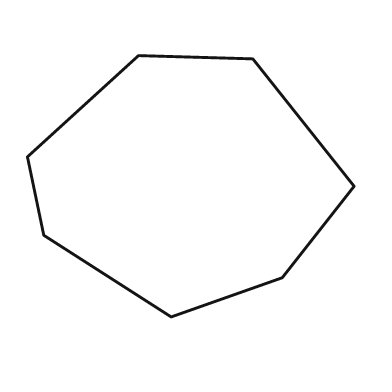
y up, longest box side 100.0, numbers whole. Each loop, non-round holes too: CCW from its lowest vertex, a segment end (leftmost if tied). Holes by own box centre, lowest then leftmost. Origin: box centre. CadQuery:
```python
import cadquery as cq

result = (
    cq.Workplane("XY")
    .moveTo(-6.0, -40.0)
    .lineTo(28.0, -28.0)
    .lineTo(50.0, 0.0)
    .lineTo(19.0, 39.0)
    .lineTo(-16.0, 40.0)
    .lineTo(-50.0, 9.0)
    .lineTo(-45.0, -15.0)
    .close()
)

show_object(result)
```